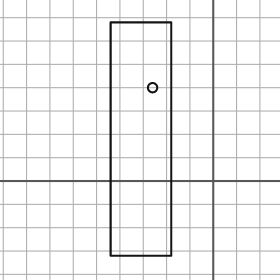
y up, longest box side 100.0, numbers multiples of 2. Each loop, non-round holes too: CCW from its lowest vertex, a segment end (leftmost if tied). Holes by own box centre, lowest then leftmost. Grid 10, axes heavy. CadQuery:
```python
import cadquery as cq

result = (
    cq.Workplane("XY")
    .moveTo(-44.0, -32.0)
    .lineTo(-18.0, -32.0)
    .lineTo(-18.0, 68.0)
    .lineTo(-44.0, 68.0)
    .close()
    .moveTo(-26.0, 40.0)
    .circle(2.0)
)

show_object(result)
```